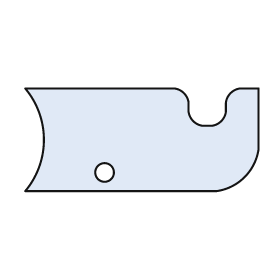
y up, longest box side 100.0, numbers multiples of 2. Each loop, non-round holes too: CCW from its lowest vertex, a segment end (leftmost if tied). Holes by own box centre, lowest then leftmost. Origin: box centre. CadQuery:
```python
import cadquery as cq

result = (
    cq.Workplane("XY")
    .moveTo(-50.0, -22.0)
    .lineTo(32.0, -22.0)
    .threePointArc((44.0, -16.0), (50.0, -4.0))
    .lineTo(50.0, 22.0)
    .lineTo(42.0, 22.0)
    .threePointArc((38.0, 20.0), (36.0, 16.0))
    .lineTo(36.0, 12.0)
    .threePointArc((34.0, 8.0), (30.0, 6.0))
    .lineTo(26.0, 6.0)
    .threePointArc((22.0, 8.0), (20.0, 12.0))
    .lineTo(20.0, 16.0)
    .threePointArc((18.0, 20.0), (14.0, 22.0))
    .lineTo(-50.0, 22.0)
    .threePointArc((-42.0, 0.0), (-50.0, -22.0))
    .close()
    .moveTo(-16.0, -14.0)
    .circle(4.0)
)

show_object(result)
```